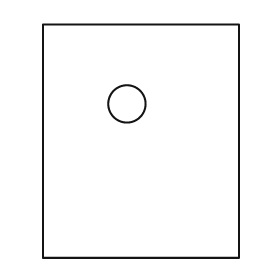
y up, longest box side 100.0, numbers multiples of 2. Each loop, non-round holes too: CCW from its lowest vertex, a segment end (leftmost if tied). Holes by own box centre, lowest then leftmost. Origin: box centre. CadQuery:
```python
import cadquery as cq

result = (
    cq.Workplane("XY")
    .moveTo(-42.0, -50.0)
    .lineTo(42.0, -50.0)
    .lineTo(42.0, 50.0)
    .lineTo(-42.0, 50.0)
    .close()
    .moveTo(-6.0, 16.0)
    .circle(8.0)
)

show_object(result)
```